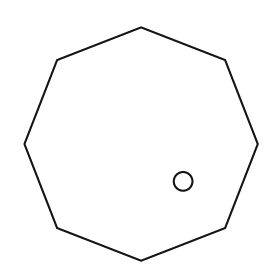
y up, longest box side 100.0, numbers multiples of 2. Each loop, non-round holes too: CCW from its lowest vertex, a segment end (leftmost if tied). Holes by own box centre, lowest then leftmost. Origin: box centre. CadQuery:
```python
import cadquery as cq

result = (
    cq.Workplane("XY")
    .moveTo(0.0, -50.0)
    .lineTo(36.0, -36.0)
    .lineTo(50.0, 0.0)
    .lineTo(36.0, 36.0)
    .lineTo(0.0, 50.0)
    .lineTo(-36.0, 36.0)
    .lineTo(-50.0, 0.0)
    .lineTo(-36.0, -36.0)
    .close()
    .moveTo(18.0, -16.0)
    .circle(4.0)
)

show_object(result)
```